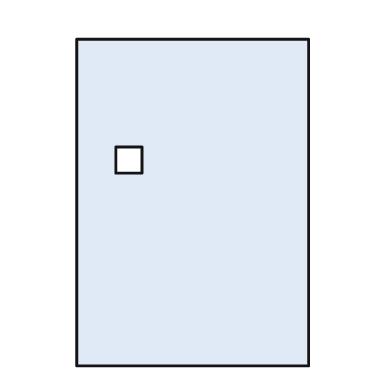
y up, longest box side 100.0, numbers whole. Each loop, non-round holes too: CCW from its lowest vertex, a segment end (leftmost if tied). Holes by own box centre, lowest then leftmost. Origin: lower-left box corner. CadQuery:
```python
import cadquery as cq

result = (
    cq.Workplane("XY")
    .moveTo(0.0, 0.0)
    .lineTo(71.0, 0.0)
    .lineTo(71.0, 100.0)
    .lineTo(0.0, 100.0)
    .close()
    .moveTo(12.0, 59.0)
    .lineTo(20.0, 59.0)
    .lineTo(20.0, 67.0)
    .lineTo(12.0, 67.0)
    .close()
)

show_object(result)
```